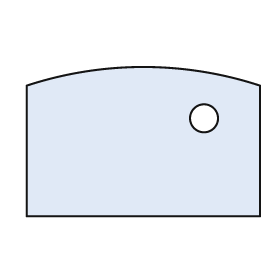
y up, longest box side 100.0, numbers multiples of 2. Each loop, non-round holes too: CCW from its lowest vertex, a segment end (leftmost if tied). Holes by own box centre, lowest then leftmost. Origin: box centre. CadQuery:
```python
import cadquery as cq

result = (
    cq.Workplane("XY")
    .moveTo(-50.0, -32.0)
    .lineTo(50.0, -32.0)
    .lineTo(50.0, 24.0)
    .threePointArc((0.0, 32.0), (-50.0, 24.0))
    .close()
    .moveTo(26.0, 10.0)
    .circle(6.0)
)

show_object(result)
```